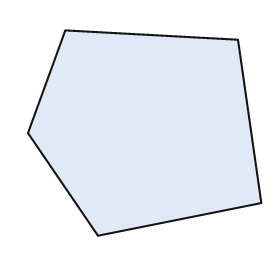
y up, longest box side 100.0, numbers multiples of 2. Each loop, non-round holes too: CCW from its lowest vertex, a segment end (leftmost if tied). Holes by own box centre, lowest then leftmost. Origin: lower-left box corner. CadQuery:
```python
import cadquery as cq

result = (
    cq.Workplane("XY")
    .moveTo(30.0, 0.0)
    .lineTo(100.0, 14.0)
    .lineTo(90.0, 84.0)
    .lineTo(16.0, 88.0)
    .lineTo(0.0, 44.0)
    .close()
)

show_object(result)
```